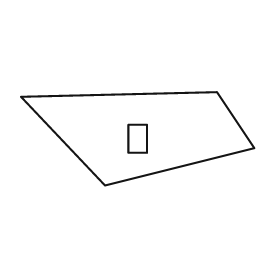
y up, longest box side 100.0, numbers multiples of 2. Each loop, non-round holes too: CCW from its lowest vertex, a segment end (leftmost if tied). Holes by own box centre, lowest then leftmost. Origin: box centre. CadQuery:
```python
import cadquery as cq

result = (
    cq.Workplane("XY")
    .moveTo(-14.0, -20.0)
    .lineTo(50.0, -4.0)
    .lineTo(34.0, 20.0)
    .lineTo(-50.0, 18.0)
    .close()
    .moveTo(-4.0, -6.0)
    .lineTo(4.0, -6.0)
    .lineTo(4.0, 6.0)
    .lineTo(-4.0, 6.0)
    .close()
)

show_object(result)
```